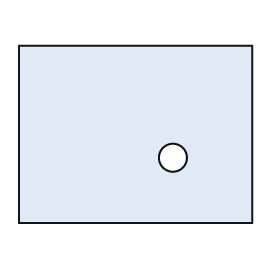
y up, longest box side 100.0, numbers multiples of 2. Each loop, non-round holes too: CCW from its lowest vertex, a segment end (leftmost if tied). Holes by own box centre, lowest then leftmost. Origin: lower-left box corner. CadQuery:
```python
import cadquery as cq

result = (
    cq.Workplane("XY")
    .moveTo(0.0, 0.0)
    .lineTo(100.0, 0.0)
    .lineTo(100.0, 76.0)
    .lineTo(0.0, 76.0)
    .close()
    .moveTo(66.0, 28.0)
    .circle(6.0)
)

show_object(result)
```